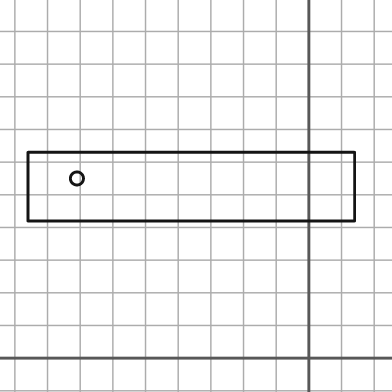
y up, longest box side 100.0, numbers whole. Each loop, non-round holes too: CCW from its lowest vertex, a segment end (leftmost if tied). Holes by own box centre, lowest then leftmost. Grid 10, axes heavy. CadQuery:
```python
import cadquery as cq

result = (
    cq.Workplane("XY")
    .moveTo(-86.0, 42.0)
    .lineTo(14.0, 42.0)
    .lineTo(14.0, 63.0)
    .lineTo(-86.0, 63.0)
    .close()
    .moveTo(-71.0, 55.0)
    .circle(2.0)
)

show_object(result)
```